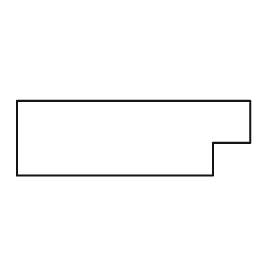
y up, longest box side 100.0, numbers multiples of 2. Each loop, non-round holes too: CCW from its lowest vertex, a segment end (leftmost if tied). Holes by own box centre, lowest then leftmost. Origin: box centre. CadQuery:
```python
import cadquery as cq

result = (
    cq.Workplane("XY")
    .moveTo(-50.0, -16.0)
    .lineTo(34.0, -16.0)
    .lineTo(34.0, -2.0)
    .lineTo(50.0, -2.0)
    .lineTo(50.0, 16.0)
    .lineTo(-50.0, 16.0)
    .close()
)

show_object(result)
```